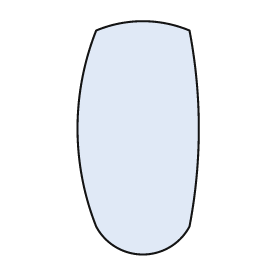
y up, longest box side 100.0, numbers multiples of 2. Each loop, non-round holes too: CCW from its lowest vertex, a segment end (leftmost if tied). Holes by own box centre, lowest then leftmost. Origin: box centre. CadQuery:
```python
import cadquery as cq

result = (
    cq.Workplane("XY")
    .moveTo(-18.0, -38.0)
    .threePointArc((2.0, -50.0), (22.0, -38.0))
    .threePointArc((26.0, 4.0), (22.0, 46.0))
    .threePointArc((2.0, 50.0), (-18.0, 46.0))
    .threePointArc((-26.0, 4.0), (-18.0, -38.0))
    .close()
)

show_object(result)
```